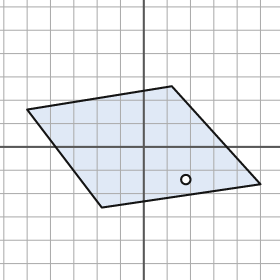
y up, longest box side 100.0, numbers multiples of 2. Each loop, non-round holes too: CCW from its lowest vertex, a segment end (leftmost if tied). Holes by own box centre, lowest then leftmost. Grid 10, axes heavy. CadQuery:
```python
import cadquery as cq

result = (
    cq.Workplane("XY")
    .moveTo(-18.0, -26.0)
    .lineTo(50.0, -16.0)
    .lineTo(12.0, 26.0)
    .lineTo(-50.0, 16.0)
    .close()
    .moveTo(18.0, -14.0)
    .circle(2.0)
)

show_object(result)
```